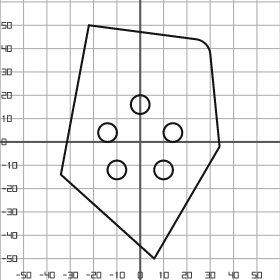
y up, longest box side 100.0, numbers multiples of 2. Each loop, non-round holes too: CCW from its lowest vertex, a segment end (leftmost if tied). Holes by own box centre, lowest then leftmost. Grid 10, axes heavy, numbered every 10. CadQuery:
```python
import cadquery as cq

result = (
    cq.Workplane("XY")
    .moveTo(6.0, -50.0)
    .lineTo(34.0, -2.0)
    .lineTo(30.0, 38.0)
    .threePointArc((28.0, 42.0), (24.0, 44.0))
    .lineTo(-22.0, 50.0)
    .lineTo(-34.0, -14.0)
    .close()
    .moveTo(-10.0, -12.0)
    .circle(4.0)
    .moveTo(10.0, -12.0)
    .circle(4.0)
    .moveTo(-14.0, 4.0)
    .circle(4.0)
    .moveTo(14.0, 4.0)
    .circle(4.0)
    .moveTo(0.0, 16.0)
    .circle(4.0)
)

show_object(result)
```